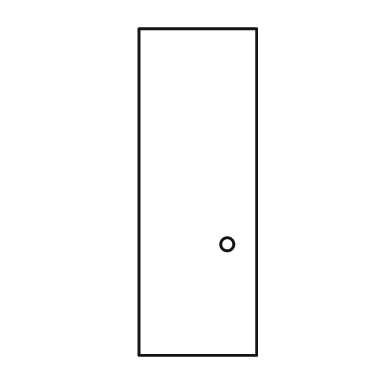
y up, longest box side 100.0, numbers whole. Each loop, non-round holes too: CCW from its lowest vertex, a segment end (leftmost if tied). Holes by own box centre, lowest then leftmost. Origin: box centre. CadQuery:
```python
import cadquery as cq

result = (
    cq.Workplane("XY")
    .moveTo(-18.0, -50.0)
    .lineTo(18.0, -50.0)
    .lineTo(18.0, 50.0)
    .lineTo(-18.0, 50.0)
    .close()
    .moveTo(9.0, -16.0)
    .circle(2.0)
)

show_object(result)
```